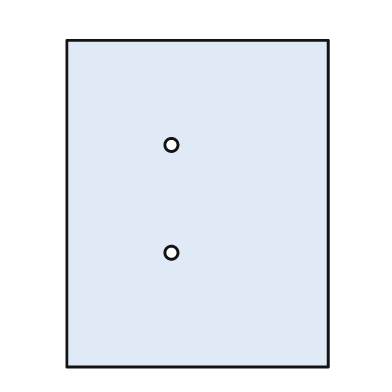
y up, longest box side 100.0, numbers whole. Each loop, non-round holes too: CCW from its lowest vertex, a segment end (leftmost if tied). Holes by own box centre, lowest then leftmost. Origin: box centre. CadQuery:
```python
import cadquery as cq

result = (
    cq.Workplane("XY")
    .moveTo(-40.0, -50.0)
    .lineTo(40.0, -50.0)
    .lineTo(40.0, 50.0)
    .lineTo(-40.0, 50.0)
    .close()
    .moveTo(-8.0, -15.0)
    .circle(2.0)
    .moveTo(-8.0, 18.0)
    .circle(2.0)
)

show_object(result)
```